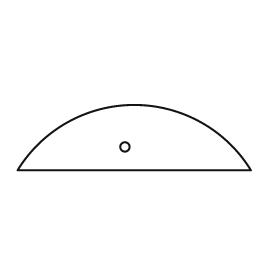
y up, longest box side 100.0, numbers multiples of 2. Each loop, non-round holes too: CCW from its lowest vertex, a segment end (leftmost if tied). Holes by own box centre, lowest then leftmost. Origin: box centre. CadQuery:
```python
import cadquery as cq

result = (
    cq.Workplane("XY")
    .moveTo(-50.0, -14.0)
    .lineTo(50.0, -14.0)
    .threePointArc((0.0, 14.0), (-50.0, -14.0))
    .close()
    .moveTo(-4.0, -4.0)
    .circle(2.0)
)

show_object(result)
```